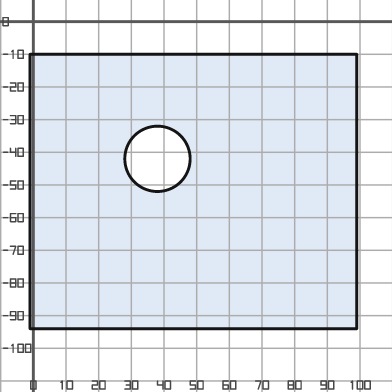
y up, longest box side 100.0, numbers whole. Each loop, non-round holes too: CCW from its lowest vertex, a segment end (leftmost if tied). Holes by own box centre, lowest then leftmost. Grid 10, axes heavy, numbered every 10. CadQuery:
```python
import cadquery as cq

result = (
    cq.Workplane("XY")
    .moveTo(-1.0, -94.0)
    .lineTo(99.0, -94.0)
    .lineTo(99.0, -10.0)
    .lineTo(-1.0, -10.0)
    .close()
    .moveTo(38.0, -42.0)
    .circle(10.0)
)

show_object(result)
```